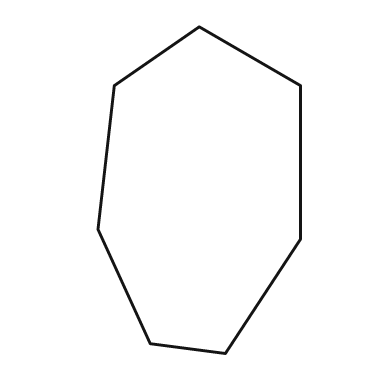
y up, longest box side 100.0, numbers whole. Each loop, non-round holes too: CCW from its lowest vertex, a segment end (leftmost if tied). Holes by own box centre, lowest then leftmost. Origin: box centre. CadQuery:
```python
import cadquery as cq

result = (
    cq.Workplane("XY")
    .moveTo(8.0, -50.0)
    .lineTo(31.0, -15.0)
    .lineTo(31.0, 32.0)
    .lineTo(0.0, 50.0)
    .lineTo(-26.0, 32.0)
    .lineTo(-31.0, -12.0)
    .lineTo(-15.0, -47.0)
    .close()
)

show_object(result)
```